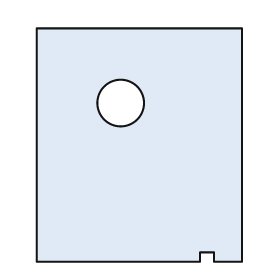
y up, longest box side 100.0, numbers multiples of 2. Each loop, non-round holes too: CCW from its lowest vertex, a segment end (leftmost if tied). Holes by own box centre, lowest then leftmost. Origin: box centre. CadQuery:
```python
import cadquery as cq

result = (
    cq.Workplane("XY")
    .moveTo(-44.0, -50.0)
    .lineTo(26.0, -50.0)
    .lineTo(26.0, -46.0)
    .lineTo(32.0, -46.0)
    .lineTo(32.0, -50.0)
    .lineTo(44.0, -50.0)
    .lineTo(44.0, 50.0)
    .lineTo(-44.0, 50.0)
    .close()
    .moveTo(-8.0, 18.0)
    .circle(10.0)
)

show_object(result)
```